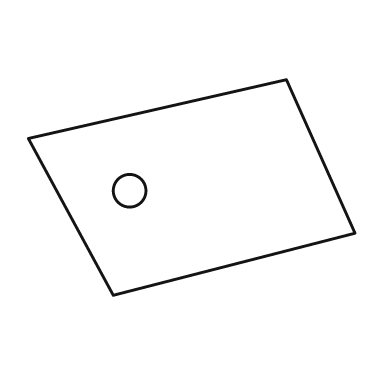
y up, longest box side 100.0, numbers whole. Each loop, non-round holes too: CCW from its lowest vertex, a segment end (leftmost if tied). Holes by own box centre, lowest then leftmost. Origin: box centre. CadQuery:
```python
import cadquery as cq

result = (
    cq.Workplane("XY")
    .moveTo(-24.0, -33.0)
    .lineTo(50.0, -14.0)
    .lineTo(29.0, 33.0)
    .lineTo(-50.0, 15.0)
    .close()
    .moveTo(-19.0, -1.0)
    .circle(5.0)
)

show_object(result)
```